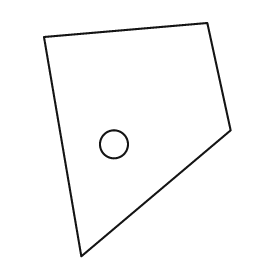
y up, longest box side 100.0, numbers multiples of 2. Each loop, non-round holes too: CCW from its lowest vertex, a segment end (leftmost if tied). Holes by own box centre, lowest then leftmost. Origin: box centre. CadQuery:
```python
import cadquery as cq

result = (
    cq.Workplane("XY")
    .moveTo(-24.0, -50.0)
    .lineTo(40.0, 4.0)
    .lineTo(30.0, 50.0)
    .lineTo(-40.0, 44.0)
    .close()
    .moveTo(-10.0, -2.0)
    .circle(6.0)
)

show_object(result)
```